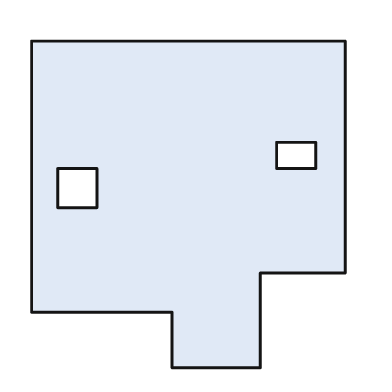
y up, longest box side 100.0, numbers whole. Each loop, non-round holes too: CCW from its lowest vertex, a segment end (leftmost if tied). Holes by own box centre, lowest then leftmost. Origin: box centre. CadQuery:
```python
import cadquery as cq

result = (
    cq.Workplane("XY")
    .moveTo(-5.0, -50.0)
    .lineTo(22.0, -50.0)
    .lineTo(22.0, -21.0)
    .lineTo(48.0, -21.0)
    .lineTo(48.0, 50.0)
    .lineTo(-48.0, 50.0)
    .lineTo(-48.0, -33.0)
    .lineTo(-5.0, -33.0)
    .close()
    .moveTo(-40.0, -1.0)
    .lineTo(-28.0, -1.0)
    .lineTo(-28.0, 11.0)
    .lineTo(-40.0, 11.0)
    .close()
    .moveTo(27.0, 11.0)
    .lineTo(39.0, 11.0)
    .lineTo(39.0, 19.0)
    .lineTo(27.0, 19.0)
    .close()
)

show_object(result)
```